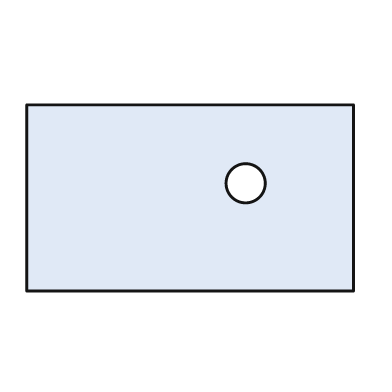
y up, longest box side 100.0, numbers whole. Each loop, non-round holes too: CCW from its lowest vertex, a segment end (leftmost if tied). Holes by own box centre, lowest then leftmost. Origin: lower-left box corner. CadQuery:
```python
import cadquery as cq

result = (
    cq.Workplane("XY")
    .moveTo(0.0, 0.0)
    .lineTo(100.0, 0.0)
    .lineTo(100.0, 57.0)
    .lineTo(0.0, 57.0)
    .close()
    .moveTo(67.0, 33.0)
    .circle(6.0)
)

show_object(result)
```